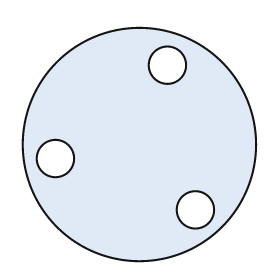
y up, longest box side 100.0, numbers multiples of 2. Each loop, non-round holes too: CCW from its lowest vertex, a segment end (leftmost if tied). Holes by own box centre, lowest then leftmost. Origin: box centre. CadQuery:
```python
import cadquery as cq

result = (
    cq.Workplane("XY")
    .moveTo(0.0, 0.0)
    .circle(50.0)
    .moveTo(24.0, -28.0)
    .circle(8.0)
    .moveTo(-36.0, -6.0)
    .circle(8.0)
    .moveTo(12.0, 34.0)
    .circle(8.0)
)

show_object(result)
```